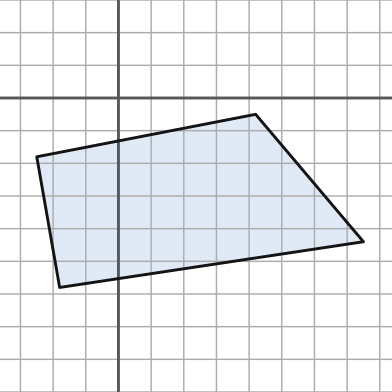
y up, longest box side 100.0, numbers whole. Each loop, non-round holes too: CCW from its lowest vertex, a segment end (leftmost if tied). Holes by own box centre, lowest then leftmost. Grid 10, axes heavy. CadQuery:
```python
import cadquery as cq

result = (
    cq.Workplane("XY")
    .moveTo(-18.0, -58.0)
    .lineTo(75.0, -44.0)
    .lineTo(42.0, -5.0)
    .lineTo(-25.0, -18.0)
    .close()
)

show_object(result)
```